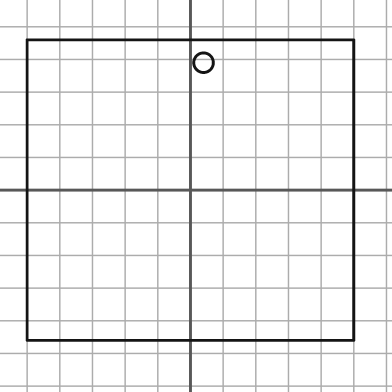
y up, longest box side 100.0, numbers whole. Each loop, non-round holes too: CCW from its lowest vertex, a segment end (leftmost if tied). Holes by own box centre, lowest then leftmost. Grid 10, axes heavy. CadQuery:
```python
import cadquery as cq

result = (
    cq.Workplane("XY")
    .moveTo(-50.0, -46.0)
    .lineTo(50.0, -46.0)
    .lineTo(50.0, 46.0)
    .lineTo(-50.0, 46.0)
    .close()
    .moveTo(4.0, 39.0)
    .circle(3.0)
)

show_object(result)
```